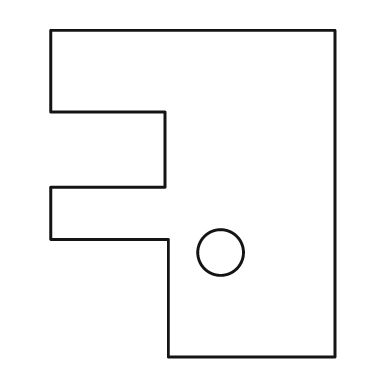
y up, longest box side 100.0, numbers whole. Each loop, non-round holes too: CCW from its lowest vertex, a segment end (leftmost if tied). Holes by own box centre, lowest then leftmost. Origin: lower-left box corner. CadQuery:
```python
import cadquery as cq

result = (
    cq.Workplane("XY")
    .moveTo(36.0, 0.0)
    .lineTo(87.0, 0.0)
    .lineTo(87.0, 100.0)
    .lineTo(0.0, 100.0)
    .lineTo(0.0, 75.0)
    .lineTo(35.0, 75.0)
    .lineTo(35.0, 52.0)
    .lineTo(0.0, 52.0)
    .lineTo(0.0, 36.0)
    .lineTo(36.0, 36.0)
    .close()
    .moveTo(52.0, 32.0)
    .circle(7.0)
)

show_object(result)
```